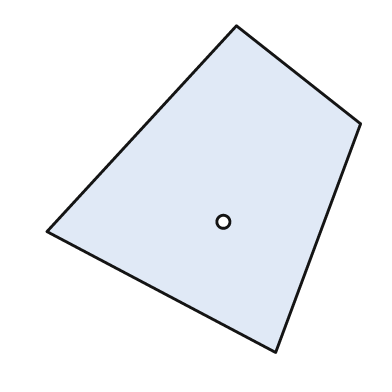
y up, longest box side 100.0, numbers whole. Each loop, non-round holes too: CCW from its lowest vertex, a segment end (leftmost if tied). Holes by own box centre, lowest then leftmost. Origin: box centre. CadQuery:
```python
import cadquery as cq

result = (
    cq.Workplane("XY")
    .moveTo(22.0, -50.0)
    .lineTo(48.0, 20.0)
    .lineTo(10.0, 50.0)
    .lineTo(-48.0, -13.0)
    .close()
    .moveTo(6.0, -10.0)
    .circle(2.0)
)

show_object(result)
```